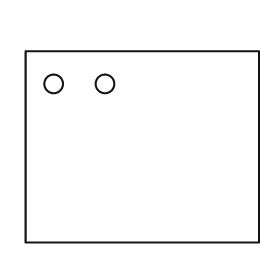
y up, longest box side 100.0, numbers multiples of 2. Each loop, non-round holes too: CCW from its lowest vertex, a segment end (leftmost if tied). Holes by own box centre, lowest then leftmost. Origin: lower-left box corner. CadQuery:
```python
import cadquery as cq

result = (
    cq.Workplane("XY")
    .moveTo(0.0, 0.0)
    .lineTo(100.0, 0.0)
    .lineTo(100.0, 82.0)
    .lineTo(0.0, 82.0)
    .close()
    .moveTo(12.0, 68.0)
    .circle(4.0)
    .moveTo(34.0, 68.0)
    .circle(4.0)
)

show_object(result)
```